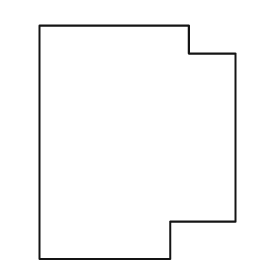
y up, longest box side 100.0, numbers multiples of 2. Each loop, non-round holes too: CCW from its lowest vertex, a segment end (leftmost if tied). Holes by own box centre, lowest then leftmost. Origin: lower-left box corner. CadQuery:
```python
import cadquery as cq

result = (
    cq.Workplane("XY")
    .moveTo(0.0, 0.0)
    .lineTo(56.0, 0.0)
    .lineTo(56.0, 16.0)
    .lineTo(84.0, 16.0)
    .lineTo(84.0, 88.0)
    .lineTo(64.0, 88.0)
    .lineTo(64.0, 100.0)
    .lineTo(0.0, 100.0)
    .close()
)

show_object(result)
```